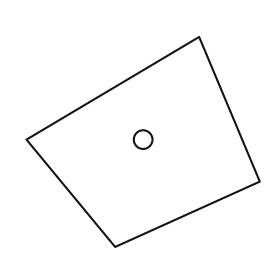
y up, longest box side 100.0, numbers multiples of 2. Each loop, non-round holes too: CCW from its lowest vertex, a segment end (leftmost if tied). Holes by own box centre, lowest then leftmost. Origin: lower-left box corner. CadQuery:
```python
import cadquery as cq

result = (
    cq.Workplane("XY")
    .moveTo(38.0, 0.0)
    .lineTo(100.0, 28.0)
    .lineTo(74.0, 90.0)
    .lineTo(0.0, 46.0)
    .close()
    .moveTo(50.0, 46.0)
    .circle(4.0)
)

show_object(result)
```